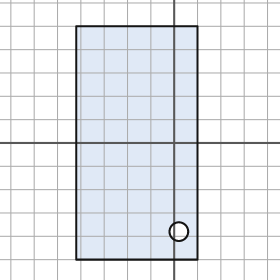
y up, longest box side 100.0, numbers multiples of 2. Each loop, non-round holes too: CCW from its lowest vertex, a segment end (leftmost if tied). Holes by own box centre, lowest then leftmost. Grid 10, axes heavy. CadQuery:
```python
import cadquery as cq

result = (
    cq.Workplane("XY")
    .moveTo(-42.0, -50.0)
    .lineTo(10.0, -50.0)
    .lineTo(10.0, 50.0)
    .lineTo(-42.0, 50.0)
    .close()
    .moveTo(2.0, -38.0)
    .circle(4.0)
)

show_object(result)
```